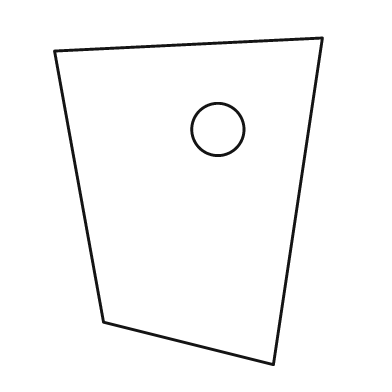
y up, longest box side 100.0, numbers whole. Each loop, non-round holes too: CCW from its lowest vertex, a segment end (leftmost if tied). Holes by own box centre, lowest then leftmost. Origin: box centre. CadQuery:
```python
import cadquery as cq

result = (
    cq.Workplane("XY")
    .moveTo(26.0, -50.0)
    .lineTo(41.0, 50.0)
    .lineTo(-41.0, 46.0)
    .lineTo(-26.0, -37.0)
    .close()
    .moveTo(9.0, 22.0)
    .circle(8.0)
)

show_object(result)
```